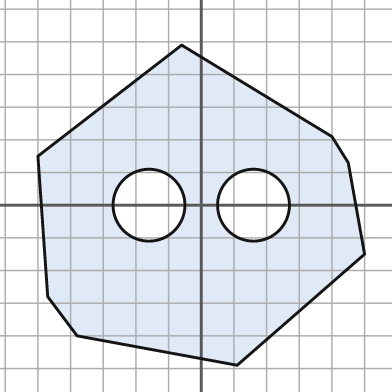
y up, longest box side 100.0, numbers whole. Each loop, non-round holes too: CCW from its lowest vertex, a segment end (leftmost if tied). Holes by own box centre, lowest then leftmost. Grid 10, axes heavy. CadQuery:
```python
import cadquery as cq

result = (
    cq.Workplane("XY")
    .moveTo(11.0, -49.0)
    .lineTo(50.0, -15.0)
    .lineTo(45.0, 13.0)
    .lineTo(40.0, 21.0)
    .lineTo(-6.0, 49.0)
    .lineTo(-50.0, 15.0)
    .lineTo(-47.0, -28.0)
    .lineTo(-38.0, -40.0)
    .close()
    .moveTo(-16.0, 0.0)
    .circle(11.0)
    .moveTo(16.0, 0.0)
    .circle(11.0)
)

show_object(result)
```